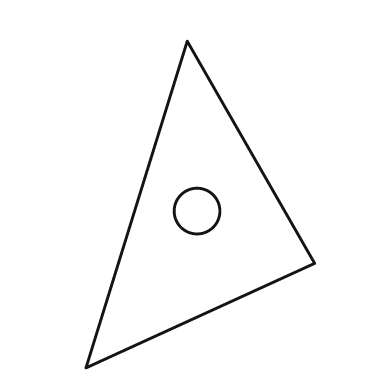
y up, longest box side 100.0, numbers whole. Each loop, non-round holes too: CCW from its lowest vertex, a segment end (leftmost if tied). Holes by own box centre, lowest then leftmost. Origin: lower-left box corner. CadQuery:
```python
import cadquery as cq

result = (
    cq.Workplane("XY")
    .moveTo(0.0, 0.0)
    .lineTo(70.0, 32.0)
    .lineTo(31.0, 100.0)
    .close()
    .moveTo(34.0, 48.0)
    .circle(7.0)
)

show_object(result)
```